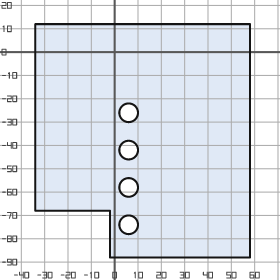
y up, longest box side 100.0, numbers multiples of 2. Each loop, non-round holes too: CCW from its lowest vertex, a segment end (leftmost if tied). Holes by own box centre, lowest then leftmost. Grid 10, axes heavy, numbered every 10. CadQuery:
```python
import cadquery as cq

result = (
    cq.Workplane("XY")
    .moveTo(-2.0, -88.0)
    .lineTo(58.0, -88.0)
    .lineTo(58.0, 12.0)
    .lineTo(-34.0, 12.0)
    .lineTo(-34.0, -68.0)
    .lineTo(-2.0, -68.0)
    .close()
    .moveTo(6.0, -74.0)
    .circle(4.0)
    .moveTo(6.0, -58.0)
    .circle(4.0)
    .moveTo(6.0, -42.0)
    .circle(4.0)
    .moveTo(6.0, -26.0)
    .circle(4.0)
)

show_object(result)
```